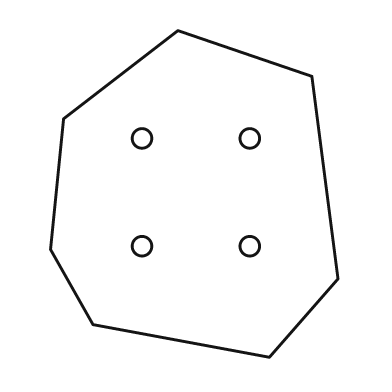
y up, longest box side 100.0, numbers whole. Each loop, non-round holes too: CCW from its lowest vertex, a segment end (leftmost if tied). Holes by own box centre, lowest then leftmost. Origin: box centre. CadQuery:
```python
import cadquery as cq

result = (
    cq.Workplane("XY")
    .moveTo(23.0, -50.0)
    .lineTo(44.0, -26.0)
    .lineTo(36.0, 36.0)
    .lineTo(-5.0, 50.0)
    .lineTo(-40.0, 23.0)
    .lineTo(-44.0, -17.0)
    .lineTo(-31.0, -40.0)
    .close()
    .moveTo(-16.0, -16.0)
    .circle(3.0)
    .moveTo(17.0, -16.0)
    .circle(3.0)
    .moveTo(-16.0, 17.0)
    .circle(3.0)
    .moveTo(17.0, 17.0)
    .circle(3.0)
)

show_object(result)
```